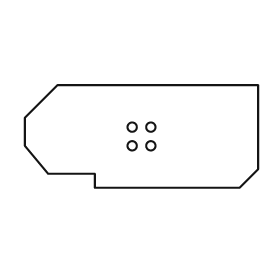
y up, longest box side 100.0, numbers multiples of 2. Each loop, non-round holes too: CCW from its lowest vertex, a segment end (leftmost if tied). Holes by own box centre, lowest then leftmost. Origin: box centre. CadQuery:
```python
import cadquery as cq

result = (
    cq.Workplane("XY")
    .moveTo(-20.0, -22.0)
    .lineTo(42.0, -22.0)
    .lineTo(50.0, -14.0)
    .lineTo(50.0, 22.0)
    .lineTo(-36.0, 22.0)
    .lineTo(-50.0, 8.0)
    .lineTo(-50.0, -4.0)
    .lineTo(-40.0, -16.0)
    .lineTo(-20.0, -16.0)
    .close()
    .moveTo(-4.0, -4.0)
    .circle(2.0)
    .moveTo(4.0, -4.0)
    .circle(2.0)
    .moveTo(-4.0, 4.0)
    .circle(2.0)
    .moveTo(4.0, 4.0)
    .circle(2.0)
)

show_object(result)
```